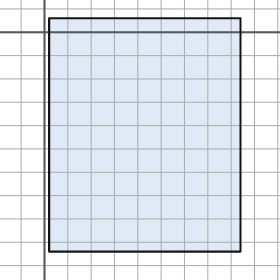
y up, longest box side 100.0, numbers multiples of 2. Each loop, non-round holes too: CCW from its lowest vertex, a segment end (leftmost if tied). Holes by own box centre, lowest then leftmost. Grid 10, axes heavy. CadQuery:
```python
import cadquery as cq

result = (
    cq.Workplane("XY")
    .moveTo(2.0, -94.0)
    .lineTo(84.0, -94.0)
    .lineTo(84.0, 6.0)
    .lineTo(2.0, 6.0)
    .close()
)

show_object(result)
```